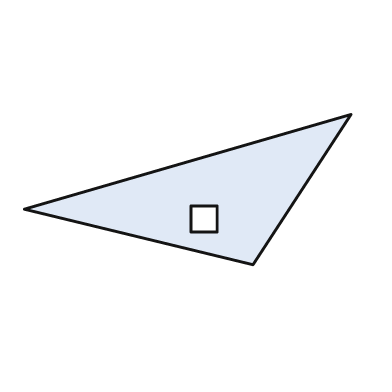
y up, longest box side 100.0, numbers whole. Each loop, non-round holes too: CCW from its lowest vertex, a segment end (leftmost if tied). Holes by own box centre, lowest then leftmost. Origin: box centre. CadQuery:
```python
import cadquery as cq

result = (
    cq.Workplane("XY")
    .moveTo(20.0, -23.0)
    .lineTo(50.0, 23.0)
    .lineTo(-50.0, -6.0)
    .close()
    .moveTo(1.0, -13.0)
    .lineTo(9.0, -13.0)
    .lineTo(9.0, -5.0)
    .lineTo(1.0, -5.0)
    .close()
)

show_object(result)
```